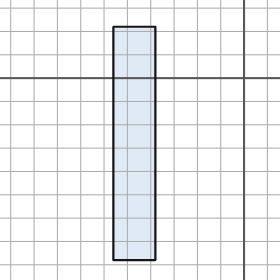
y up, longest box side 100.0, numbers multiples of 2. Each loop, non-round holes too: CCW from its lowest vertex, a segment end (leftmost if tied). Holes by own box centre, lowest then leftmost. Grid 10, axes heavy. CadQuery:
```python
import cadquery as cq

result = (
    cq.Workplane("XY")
    .moveTo(-56.0, -78.0)
    .lineTo(-38.0, -78.0)
    .lineTo(-38.0, 22.0)
    .lineTo(-56.0, 22.0)
    .close()
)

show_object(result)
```